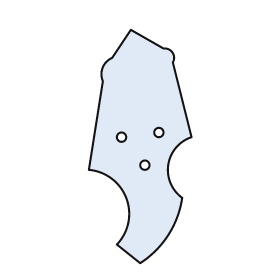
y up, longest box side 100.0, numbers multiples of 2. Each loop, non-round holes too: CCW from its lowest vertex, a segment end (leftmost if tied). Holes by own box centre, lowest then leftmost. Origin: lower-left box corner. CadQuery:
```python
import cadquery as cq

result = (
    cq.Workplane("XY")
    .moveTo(22.0, 0.0)
    .threePointArc((34.0, 12.0), (40.0, 28.0))
    .threePointArc((34.0, 42.0), (44.0, 54.0))
    .lineTo(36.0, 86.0)
    .threePointArc((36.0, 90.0), (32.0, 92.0))
    .lineTo(18.0, 100.0)
    .lineTo(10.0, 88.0)
    .threePointArc((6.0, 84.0), (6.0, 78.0))
    .lineTo(0.0, 40.0)
    .threePointArc((16.0, 28.0), (12.0, 8.0))
    .close()
    .moveTo(24.0, 42.0)
    .circle(2.0)
    .moveTo(14.0, 54.0)
    .circle(2.0)
    .moveTo(30.0, 56.0)
    .circle(2.0)
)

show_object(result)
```